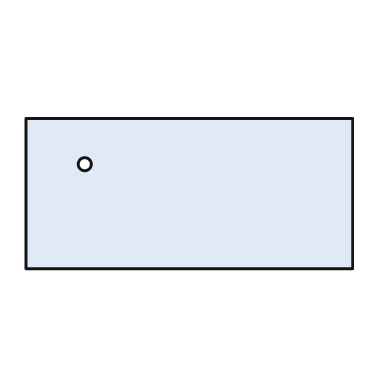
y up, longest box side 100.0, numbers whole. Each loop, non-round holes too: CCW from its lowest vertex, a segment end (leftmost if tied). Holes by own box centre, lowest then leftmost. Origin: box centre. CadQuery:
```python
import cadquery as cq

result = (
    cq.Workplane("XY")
    .moveTo(-50.0, -23.0)
    .lineTo(50.0, -23.0)
    .lineTo(50.0, 23.0)
    .lineTo(-50.0, 23.0)
    .close()
    .moveTo(-32.0, 9.0)
    .circle(2.0)
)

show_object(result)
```